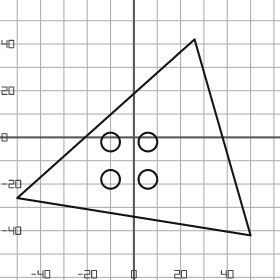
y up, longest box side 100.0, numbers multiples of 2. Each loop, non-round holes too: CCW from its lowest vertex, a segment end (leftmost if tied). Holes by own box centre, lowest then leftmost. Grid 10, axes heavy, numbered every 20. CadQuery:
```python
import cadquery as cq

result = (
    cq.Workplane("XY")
    .moveTo(50.0, -42.0)
    .lineTo(26.0, 42.0)
    .lineTo(-50.0, -26.0)
    .close()
    .moveTo(-10.0, -18.0)
    .circle(4.0)
    .moveTo(6.0, -18.0)
    .circle(4.0)
    .moveTo(-10.0, -2.0)
    .circle(4.0)
    .moveTo(6.0, -2.0)
    .circle(4.0)
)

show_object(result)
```